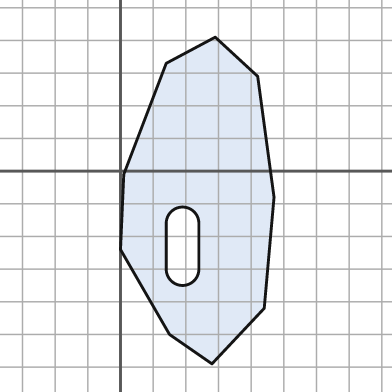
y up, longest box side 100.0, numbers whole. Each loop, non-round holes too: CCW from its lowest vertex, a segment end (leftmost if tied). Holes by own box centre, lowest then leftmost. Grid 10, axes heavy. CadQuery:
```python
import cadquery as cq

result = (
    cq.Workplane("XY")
    .moveTo(28.0, -59.0)
    .lineTo(44.0, -42.0)
    .lineTo(47.0, -8.0)
    .lineTo(42.0, 29.0)
    .lineTo(29.0, 41.0)
    .lineTo(14.0, 33.0)
    .lineTo(1.0, -1.0)
    .lineTo(0.0, -24.0)
    .lineTo(15.0, -50.0)
    .close()
    .moveTo(14.0, -30.0)
    .threePointArc((19.0, -35.0), (24.0, -30.0))
    .lineTo(24.0, -16.0)
    .threePointArc((19.0, -11.0), (14.0, -16.0))
    .close()
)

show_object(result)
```